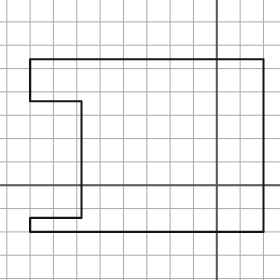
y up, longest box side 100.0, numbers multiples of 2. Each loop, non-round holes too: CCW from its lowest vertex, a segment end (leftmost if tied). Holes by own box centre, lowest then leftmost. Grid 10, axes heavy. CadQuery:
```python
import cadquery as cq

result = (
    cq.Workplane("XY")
    .moveTo(-80.0, -20.0)
    .lineTo(20.0, -20.0)
    .lineTo(20.0, 54.0)
    .lineTo(-80.0, 54.0)
    .lineTo(-80.0, 36.0)
    .lineTo(-58.0, 36.0)
    .lineTo(-58.0, -14.0)
    .lineTo(-80.0, -14.0)
    .close()
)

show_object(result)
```